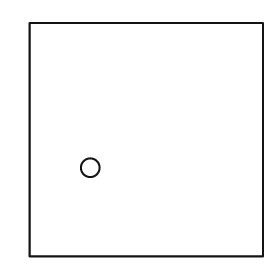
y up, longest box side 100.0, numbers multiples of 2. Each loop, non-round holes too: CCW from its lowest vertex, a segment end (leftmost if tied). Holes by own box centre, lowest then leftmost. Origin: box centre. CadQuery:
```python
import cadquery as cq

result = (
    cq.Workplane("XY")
    .moveTo(-50.0, -50.0)
    .lineTo(50.0, -50.0)
    .lineTo(50.0, 50.0)
    .lineTo(-50.0, 50.0)
    .close()
    .moveTo(-24.0, -12.0)
    .circle(4.0)
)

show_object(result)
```